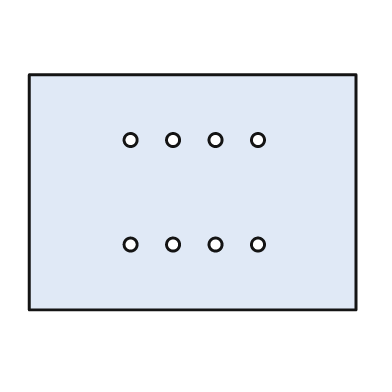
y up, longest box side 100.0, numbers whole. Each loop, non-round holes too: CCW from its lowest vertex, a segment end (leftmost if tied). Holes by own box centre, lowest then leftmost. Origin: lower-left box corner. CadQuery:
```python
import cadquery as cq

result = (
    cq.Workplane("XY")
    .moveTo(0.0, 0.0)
    .lineTo(100.0, 0.0)
    .lineTo(100.0, 72.0)
    .lineTo(0.0, 72.0)
    .close()
    .moveTo(31.0, 20.0)
    .circle(2.0)
    .moveTo(44.0, 20.0)
    .circle(2.0)
    .moveTo(57.0, 20.0)
    .circle(2.0)
    .moveTo(70.0, 20.0)
    .circle(2.0)
    .moveTo(31.0, 52.0)
    .circle(2.0)
    .moveTo(44.0, 52.0)
    .circle(2.0)
    .moveTo(57.0, 52.0)
    .circle(2.0)
    .moveTo(70.0, 52.0)
    .circle(2.0)
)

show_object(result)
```